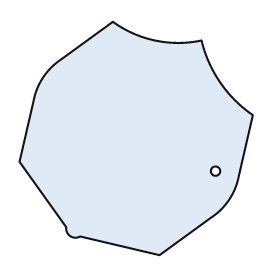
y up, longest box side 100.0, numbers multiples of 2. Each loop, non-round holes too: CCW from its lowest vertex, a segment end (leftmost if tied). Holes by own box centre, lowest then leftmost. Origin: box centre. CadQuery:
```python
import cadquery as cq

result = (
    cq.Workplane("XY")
    .moveTo(10.0, -50.0)
    .lineTo(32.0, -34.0)
    .threePointArc((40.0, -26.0), (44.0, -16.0))
    .lineTo(50.0, 10.0)
    .threePointArc((36.0, 24.0), (28.0, 42.0))
    .threePointArc((8.0, 42.0), (-10.0, 50.0))
    .lineTo(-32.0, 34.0)
    .threePointArc((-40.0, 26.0), (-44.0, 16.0))
    .lineTo(-50.0, -10.0)
    .lineTo(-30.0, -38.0)
    .threePointArc((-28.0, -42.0), (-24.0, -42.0))
    .close()
    .moveTo(34.0, -14.0)
    .circle(2.0)
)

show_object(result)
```